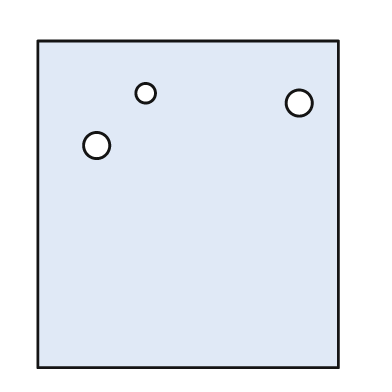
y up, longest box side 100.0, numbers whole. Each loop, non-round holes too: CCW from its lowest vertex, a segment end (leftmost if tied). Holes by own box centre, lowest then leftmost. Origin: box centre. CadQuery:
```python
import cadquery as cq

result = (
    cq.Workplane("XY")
    .moveTo(-46.0, -50.0)
    .lineTo(46.0, -50.0)
    .lineTo(46.0, 50.0)
    .lineTo(-46.0, 50.0)
    .close()
    .moveTo(-28.0, 18.0)
    .circle(4.0)
    .moveTo(34.0, 31.0)
    .circle(4.0)
    .moveTo(-13.0, 34.0)
    .circle(3.0)
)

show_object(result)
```